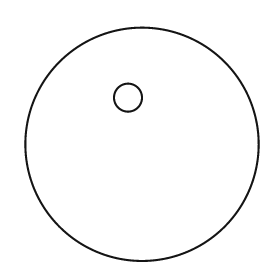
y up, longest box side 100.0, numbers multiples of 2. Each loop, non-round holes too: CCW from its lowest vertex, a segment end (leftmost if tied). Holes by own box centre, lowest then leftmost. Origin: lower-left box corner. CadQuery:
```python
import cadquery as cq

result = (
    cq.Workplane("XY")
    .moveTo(50.0, 50.0)
    .circle(50.0)
    .moveTo(44.0, 70.0)
    .circle(6.0)
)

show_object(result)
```